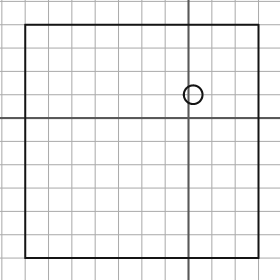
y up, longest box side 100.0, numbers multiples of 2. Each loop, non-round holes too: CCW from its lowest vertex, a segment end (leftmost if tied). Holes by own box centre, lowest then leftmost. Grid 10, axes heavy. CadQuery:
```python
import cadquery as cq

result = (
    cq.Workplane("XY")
    .moveTo(-70.0, -60.0)
    .lineTo(30.0, -60.0)
    .lineTo(30.0, 40.0)
    .lineTo(-70.0, 40.0)
    .close()
    .moveTo(2.0, 10.0)
    .circle(4.0)
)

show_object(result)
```